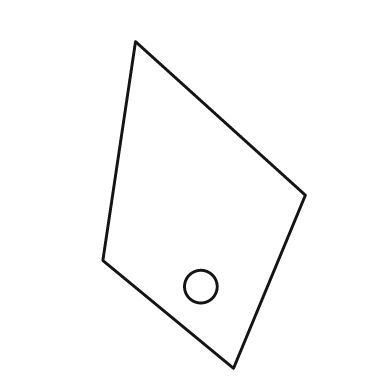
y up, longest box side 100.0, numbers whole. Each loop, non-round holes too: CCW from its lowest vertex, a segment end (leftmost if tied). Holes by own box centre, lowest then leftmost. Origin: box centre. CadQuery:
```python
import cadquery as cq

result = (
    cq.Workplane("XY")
    .moveTo(9.0, -50.0)
    .lineTo(31.0, 3.0)
    .lineTo(-21.0, 50.0)
    .lineTo(-31.0, -17.0)
    .close()
    .moveTo(-1.0, -25.0)
    .circle(5.0)
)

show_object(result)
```